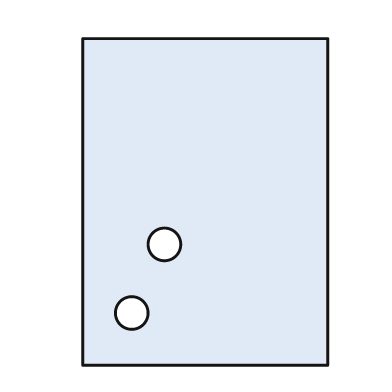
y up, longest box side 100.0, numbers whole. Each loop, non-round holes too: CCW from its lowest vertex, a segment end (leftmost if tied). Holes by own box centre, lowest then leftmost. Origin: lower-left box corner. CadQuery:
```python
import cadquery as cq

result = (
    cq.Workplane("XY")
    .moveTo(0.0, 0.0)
    .lineTo(75.0, 0.0)
    .lineTo(75.0, 100.0)
    .lineTo(0.0, 100.0)
    .close()
    .moveTo(15.0, 16.0)
    .circle(5.0)
    .moveTo(25.0, 37.0)
    .circle(5.0)
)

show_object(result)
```